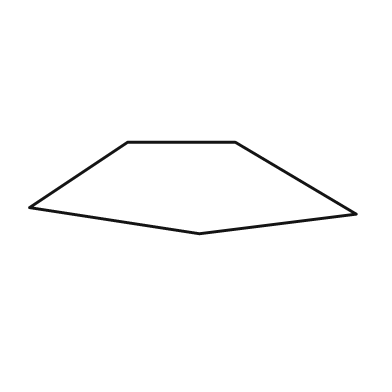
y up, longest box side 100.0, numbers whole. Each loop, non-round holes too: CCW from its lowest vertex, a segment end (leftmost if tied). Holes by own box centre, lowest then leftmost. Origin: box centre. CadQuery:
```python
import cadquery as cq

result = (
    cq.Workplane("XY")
    .moveTo(2.0, -14.0)
    .lineTo(50.0, -8.0)
    .lineTo(13.0, 14.0)
    .lineTo(-20.0, 14.0)
    .lineTo(-50.0, -6.0)
    .close()
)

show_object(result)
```